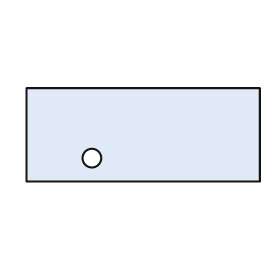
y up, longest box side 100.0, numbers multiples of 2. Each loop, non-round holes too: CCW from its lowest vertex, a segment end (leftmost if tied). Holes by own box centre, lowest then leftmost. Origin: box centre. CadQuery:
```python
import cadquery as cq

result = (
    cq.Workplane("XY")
    .moveTo(-50.0, -20.0)
    .lineTo(50.0, -20.0)
    .lineTo(50.0, 20.0)
    .lineTo(-50.0, 20.0)
    .close()
    .moveTo(-22.0, -10.0)
    .circle(4.0)
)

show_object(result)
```